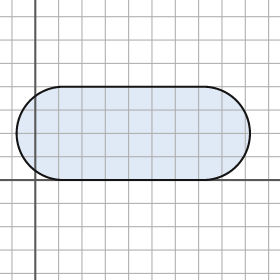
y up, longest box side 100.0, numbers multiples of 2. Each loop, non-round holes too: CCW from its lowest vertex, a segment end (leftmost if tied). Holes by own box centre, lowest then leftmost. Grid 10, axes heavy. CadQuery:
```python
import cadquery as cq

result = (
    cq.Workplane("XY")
    .moveTo(12.0, 0.0)
    .lineTo(72.0, 0.0)
    .threePointArc((92.0, 20.0), (72.0, 40.0))
    .lineTo(12.0, 40.0)
    .threePointArc((-8.0, 20.0), (12.0, 0.0))
    .close()
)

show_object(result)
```